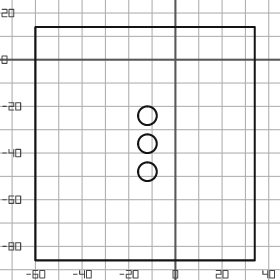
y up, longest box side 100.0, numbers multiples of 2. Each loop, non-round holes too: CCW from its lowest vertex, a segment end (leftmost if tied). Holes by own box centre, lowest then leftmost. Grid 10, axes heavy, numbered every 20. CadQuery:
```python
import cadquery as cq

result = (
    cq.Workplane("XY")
    .moveTo(-60.0, -86.0)
    .lineTo(34.0, -86.0)
    .lineTo(34.0, 14.0)
    .lineTo(-60.0, 14.0)
    .close()
    .moveTo(-12.0, -48.0)
    .circle(4.0)
    .moveTo(-12.0, -36.0)
    .circle(4.0)
    .moveTo(-12.0, -24.0)
    .circle(4.0)
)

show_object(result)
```